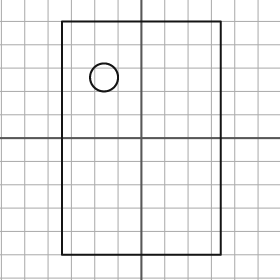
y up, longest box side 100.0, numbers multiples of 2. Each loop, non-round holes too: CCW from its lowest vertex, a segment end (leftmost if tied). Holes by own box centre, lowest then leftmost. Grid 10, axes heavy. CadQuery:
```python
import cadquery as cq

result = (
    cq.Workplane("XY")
    .moveTo(-34.0, -50.0)
    .lineTo(34.0, -50.0)
    .lineTo(34.0, 50.0)
    .lineTo(-34.0, 50.0)
    .close()
    .moveTo(-16.0, 26.0)
    .circle(6.0)
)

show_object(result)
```